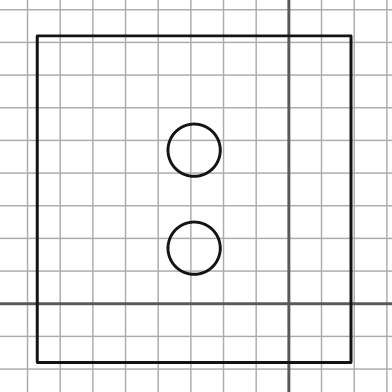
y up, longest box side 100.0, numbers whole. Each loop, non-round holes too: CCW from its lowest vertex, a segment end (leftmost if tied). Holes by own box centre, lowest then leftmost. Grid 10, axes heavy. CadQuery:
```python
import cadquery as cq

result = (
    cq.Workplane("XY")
    .moveTo(-77.0, -18.0)
    .lineTo(19.0, -18.0)
    .lineTo(19.0, 82.0)
    .lineTo(-77.0, 82.0)
    .close()
    .moveTo(-29.0, 17.0)
    .circle(8.0)
    .moveTo(-29.0, 47.0)
    .circle(8.0)
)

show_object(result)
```